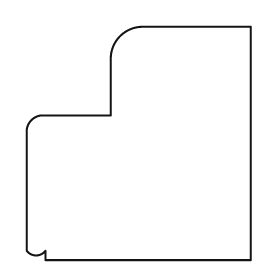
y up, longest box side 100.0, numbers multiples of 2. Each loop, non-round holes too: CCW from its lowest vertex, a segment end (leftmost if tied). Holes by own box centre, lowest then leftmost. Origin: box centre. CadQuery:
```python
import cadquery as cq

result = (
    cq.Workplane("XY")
    .moveTo(-40.0, -50.0)
    .lineTo(48.0, -50.0)
    .lineTo(48.0, 50.0)
    .lineTo(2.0, 50.0)
    .threePointArc((-8.0, 46.0), (-12.0, 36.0))
    .lineTo(-12.0, 12.0)
    .lineTo(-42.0, 12.0)
    .threePointArc((-46.0, 10.0), (-48.0, 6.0))
    .lineTo(-48.0, -46.0)
    .threePointArc((-44.0, -48.0), (-40.0, -46.0))
    .close()
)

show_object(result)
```